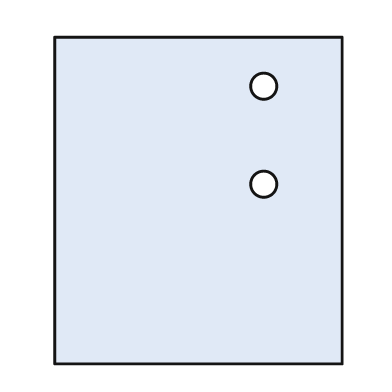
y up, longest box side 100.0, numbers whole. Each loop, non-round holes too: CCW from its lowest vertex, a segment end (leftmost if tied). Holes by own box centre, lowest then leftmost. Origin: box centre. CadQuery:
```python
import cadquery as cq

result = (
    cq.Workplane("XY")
    .moveTo(-44.0, -50.0)
    .lineTo(44.0, -50.0)
    .lineTo(44.0, 50.0)
    .lineTo(-44.0, 50.0)
    .close()
    .moveTo(20.0, 5.0)
    .circle(4.0)
    .moveTo(20.0, 35.0)
    .circle(4.0)
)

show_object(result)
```